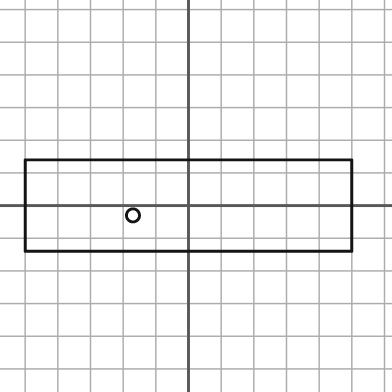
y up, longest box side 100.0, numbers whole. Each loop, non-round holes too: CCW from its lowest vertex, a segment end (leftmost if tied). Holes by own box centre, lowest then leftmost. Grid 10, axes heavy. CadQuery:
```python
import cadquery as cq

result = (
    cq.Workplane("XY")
    .moveTo(-50.0, -14.0)
    .lineTo(50.0, -14.0)
    .lineTo(50.0, 14.0)
    .lineTo(-50.0, 14.0)
    .close()
    .moveTo(-17.0, -3.0)
    .circle(2.0)
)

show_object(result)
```